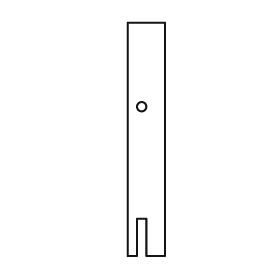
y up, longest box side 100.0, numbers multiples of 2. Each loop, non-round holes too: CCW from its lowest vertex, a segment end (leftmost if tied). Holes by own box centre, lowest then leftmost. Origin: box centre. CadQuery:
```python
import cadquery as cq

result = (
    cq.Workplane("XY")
    .moveTo(-8.0, -50.0)
    .lineTo(-4.0, -50.0)
    .lineTo(-4.0, -34.0)
    .lineTo(0.0, -34.0)
    .lineTo(0.0, -50.0)
    .lineTo(8.0, -50.0)
    .lineTo(8.0, 50.0)
    .lineTo(-8.0, 50.0)
    .close()
    .moveTo(-2.0, 14.0)
    .circle(2.0)
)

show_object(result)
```